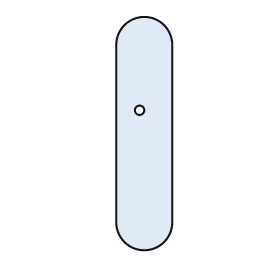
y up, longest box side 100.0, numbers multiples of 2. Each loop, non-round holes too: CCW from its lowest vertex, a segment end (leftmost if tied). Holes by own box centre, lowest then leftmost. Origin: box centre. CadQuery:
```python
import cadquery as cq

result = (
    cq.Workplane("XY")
    .moveTo(-12.0, -38.0)
    .threePointArc((0.0, -50.0), (12.0, -38.0))
    .lineTo(12.0, 38.0)
    .threePointArc((0.0, 50.0), (-12.0, 38.0))
    .close()
    .moveTo(-2.0, 10.0)
    .circle(2.0)
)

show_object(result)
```